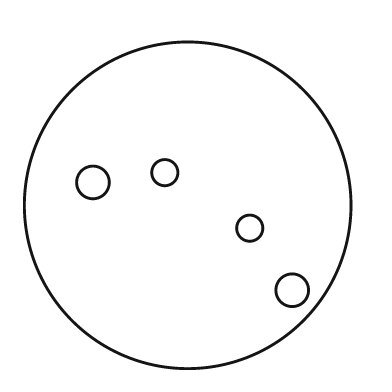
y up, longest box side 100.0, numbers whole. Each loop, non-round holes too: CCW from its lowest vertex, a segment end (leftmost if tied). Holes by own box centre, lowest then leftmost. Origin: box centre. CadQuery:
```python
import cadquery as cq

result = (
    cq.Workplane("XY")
    .moveTo(0.0, 0.0)
    .circle(50.0)
    .moveTo(32.0, -26.0)
    .circle(5.0)
    .moveTo(19.0, -7.0)
    .circle(4.0)
    .moveTo(-29.0, 7.0)
    .circle(5.0)
    .moveTo(-7.0, 10.0)
    .circle(4.0)
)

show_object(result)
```